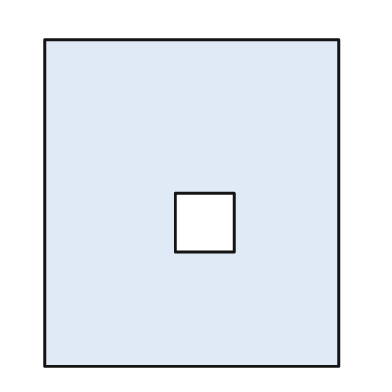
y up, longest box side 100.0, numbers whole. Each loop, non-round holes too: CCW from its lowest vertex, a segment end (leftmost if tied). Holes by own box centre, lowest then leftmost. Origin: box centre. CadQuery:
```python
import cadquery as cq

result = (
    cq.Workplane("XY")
    .moveTo(-45.0, -50.0)
    .lineTo(45.0, -50.0)
    .lineTo(45.0, 50.0)
    .lineTo(-45.0, 50.0)
    .close()
    .moveTo(-5.0, -15.0)
    .lineTo(13.0, -15.0)
    .lineTo(13.0, 3.0)
    .lineTo(-5.0, 3.0)
    .close()
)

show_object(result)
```